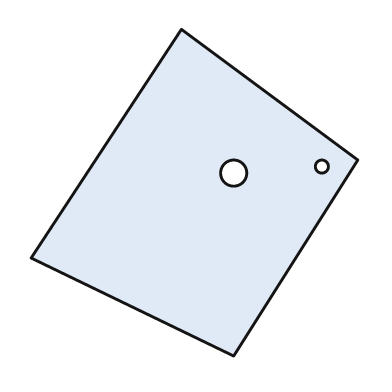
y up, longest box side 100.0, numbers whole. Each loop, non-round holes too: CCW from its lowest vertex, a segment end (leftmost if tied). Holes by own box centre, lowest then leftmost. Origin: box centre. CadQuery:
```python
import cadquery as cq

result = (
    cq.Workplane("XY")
    .moveTo(12.0, -50.0)
    .lineTo(50.0, 10.0)
    .lineTo(-4.0, 50.0)
    .lineTo(-50.0, -20.0)
    .close()
    .moveTo(12.0, 6.0)
    .circle(4.0)
    .moveTo(39.0, 8.0)
    .circle(2.0)
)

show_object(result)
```